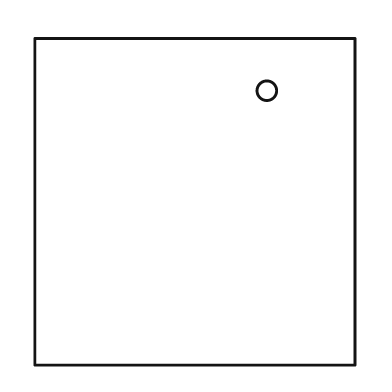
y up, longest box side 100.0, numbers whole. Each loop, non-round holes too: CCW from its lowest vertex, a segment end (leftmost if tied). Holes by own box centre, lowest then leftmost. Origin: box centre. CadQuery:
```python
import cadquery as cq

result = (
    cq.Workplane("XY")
    .moveTo(-49.0, -50.0)
    .lineTo(49.0, -50.0)
    .lineTo(49.0, 50.0)
    .lineTo(-49.0, 50.0)
    .close()
    .moveTo(22.0, 34.0)
    .circle(3.0)
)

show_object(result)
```